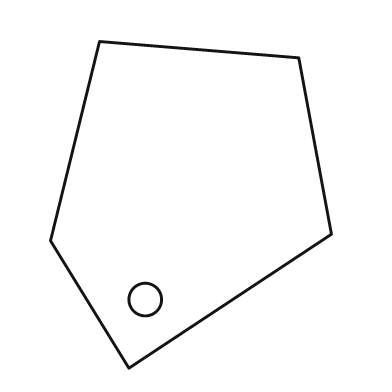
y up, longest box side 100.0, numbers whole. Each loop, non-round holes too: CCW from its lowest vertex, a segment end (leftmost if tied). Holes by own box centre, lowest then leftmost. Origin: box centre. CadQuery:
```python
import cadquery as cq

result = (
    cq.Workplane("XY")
    .moveTo(-19.0, -50.0)
    .lineTo(43.0, -9.0)
    .lineTo(33.0, 45.0)
    .lineTo(-28.0, 50.0)
    .lineTo(-43.0, -11.0)
    .close()
    .moveTo(-14.0, -29.0)
    .circle(5.0)
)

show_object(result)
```